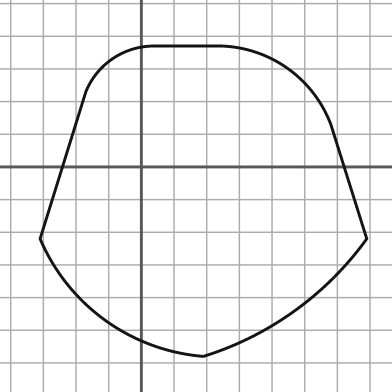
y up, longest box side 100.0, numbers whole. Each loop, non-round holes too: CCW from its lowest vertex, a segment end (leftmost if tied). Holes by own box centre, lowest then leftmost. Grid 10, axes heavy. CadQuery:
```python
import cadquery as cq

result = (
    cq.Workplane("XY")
    .moveTo(19.0, -58.0)
    .threePointArc((47.0, -44.0), (69.0, -22.0))
    .lineTo(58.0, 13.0)
    .threePointArc((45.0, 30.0), (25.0, 37.0))
    .lineTo(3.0, 37.0)
    .threePointArc((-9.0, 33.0), (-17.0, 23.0))
    .lineTo(-31.0, -22.0)
    .threePointArc((-11.0, -47.0), (19.0, -58.0))
    .close()
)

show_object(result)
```